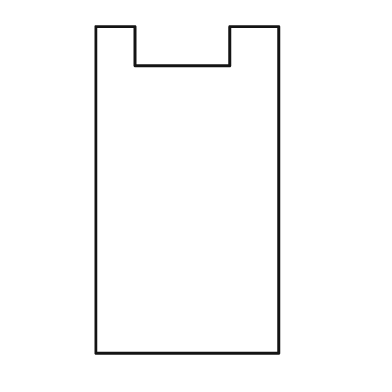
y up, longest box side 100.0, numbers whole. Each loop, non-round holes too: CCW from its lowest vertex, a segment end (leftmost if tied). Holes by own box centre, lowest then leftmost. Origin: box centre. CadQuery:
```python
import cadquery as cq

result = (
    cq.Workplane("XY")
    .moveTo(-28.0, -50.0)
    .lineTo(28.0, -50.0)
    .lineTo(28.0, 50.0)
    .lineTo(13.0, 50.0)
    .lineTo(13.0, 38.0)
    .lineTo(-16.0, 38.0)
    .lineTo(-16.0, 50.0)
    .lineTo(-28.0, 50.0)
    .close()
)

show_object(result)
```